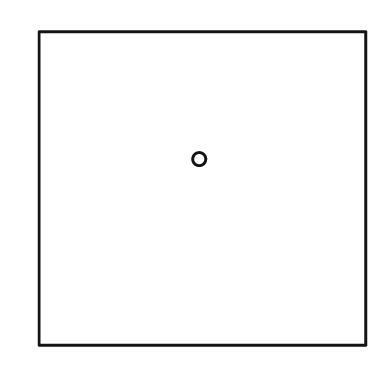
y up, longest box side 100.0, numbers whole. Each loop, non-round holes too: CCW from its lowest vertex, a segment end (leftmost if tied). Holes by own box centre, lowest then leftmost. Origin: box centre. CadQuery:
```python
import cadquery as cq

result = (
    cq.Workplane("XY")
    .moveTo(-50.0, -48.0)
    .lineTo(50.0, -48.0)
    .lineTo(50.0, 48.0)
    .lineTo(-50.0, 48.0)
    .close()
    .moveTo(-1.0, 9.0)
    .circle(2.0)
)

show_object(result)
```